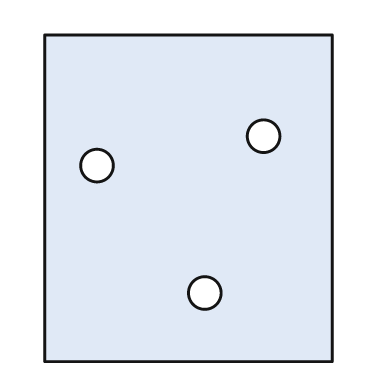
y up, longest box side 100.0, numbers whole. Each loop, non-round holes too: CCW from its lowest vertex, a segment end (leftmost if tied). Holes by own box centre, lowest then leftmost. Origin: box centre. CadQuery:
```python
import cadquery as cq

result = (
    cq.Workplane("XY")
    .moveTo(-44.0, -50.0)
    .lineTo(44.0, -50.0)
    .lineTo(44.0, 50.0)
    .lineTo(-44.0, 50.0)
    .close()
    .moveTo(5.0, -29.0)
    .circle(5.0)
    .moveTo(-28.0, 10.0)
    .circle(5.0)
    .moveTo(23.0, 19.0)
    .circle(5.0)
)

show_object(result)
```